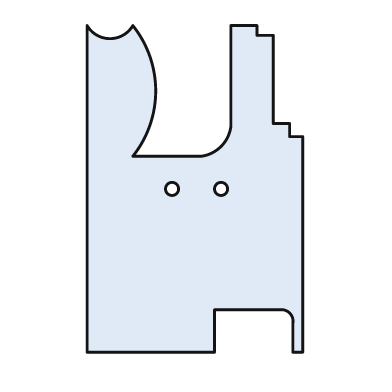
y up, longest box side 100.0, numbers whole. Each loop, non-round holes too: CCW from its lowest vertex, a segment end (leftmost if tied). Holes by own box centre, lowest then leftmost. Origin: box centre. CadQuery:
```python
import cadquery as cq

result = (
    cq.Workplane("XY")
    .moveTo(-33.0, -50.0)
    .lineTo(6.0, -50.0)
    .lineTo(6.0, -37.0)
    .lineTo(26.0, -37.0)
    .threePointArc((29.0, -38.0), (30.0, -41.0))
    .lineTo(30.0, -50.0)
    .lineTo(33.0, -50.0)
    .lineTo(33.0, 16.0)
    .lineTo(29.0, 16.0)
    .lineTo(29.0, 20.0)
    .lineTo(24.0, 20.0)
    .lineTo(24.0, 47.0)
    .lineTo(19.0, 47.0)
    .lineTo(19.0, 50.0)
    .lineTo(11.0, 50.0)
    .lineTo(11.0, 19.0)
    .threePointArc((8.0, 13.0), (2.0, 10.0))
    .lineTo(-19.0, 10.0)
    .threePointArc((-12.0, 30.0), (-19.0, 50.0))
    .threePointArc((-26.0, 46.0), (-33.0, 50.0))
    .close()
    .moveTo(-7.0, 0.0)
    .circle(2.0)
    .moveTo(8.0, 0.0)
    .circle(2.0)
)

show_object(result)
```